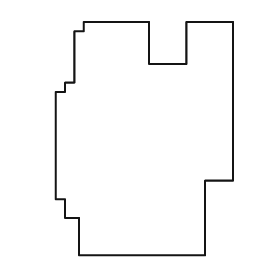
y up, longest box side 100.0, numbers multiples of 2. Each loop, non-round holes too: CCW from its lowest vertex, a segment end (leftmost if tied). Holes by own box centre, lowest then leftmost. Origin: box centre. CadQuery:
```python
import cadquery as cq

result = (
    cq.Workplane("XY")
    .moveTo(-28.0, -50.0)
    .lineTo(26.0, -50.0)
    .lineTo(26.0, -18.0)
    .lineTo(38.0, -18.0)
    .lineTo(38.0, 50.0)
    .lineTo(18.0, 50.0)
    .lineTo(18.0, 32.0)
    .lineTo(2.0, 32.0)
    .lineTo(2.0, 50.0)
    .lineTo(-26.0, 50.0)
    .lineTo(-26.0, 46.0)
    .lineTo(-30.0, 46.0)
    .lineTo(-30.0, 24.0)
    .lineTo(-34.0, 24.0)
    .lineTo(-34.0, 20.0)
    .lineTo(-38.0, 20.0)
    .lineTo(-38.0, -26.0)
    .lineTo(-34.0, -26.0)
    .lineTo(-34.0, -34.0)
    .lineTo(-28.0, -34.0)
    .close()
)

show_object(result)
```